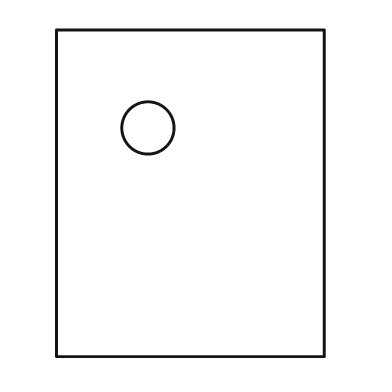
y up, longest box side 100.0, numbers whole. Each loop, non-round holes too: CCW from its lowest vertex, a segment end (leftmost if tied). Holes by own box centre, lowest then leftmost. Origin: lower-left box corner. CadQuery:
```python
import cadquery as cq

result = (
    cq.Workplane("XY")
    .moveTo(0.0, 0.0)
    .lineTo(82.0, 0.0)
    .lineTo(82.0, 100.0)
    .lineTo(0.0, 100.0)
    .close()
    .moveTo(28.0, 70.0)
    .circle(8.0)
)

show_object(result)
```